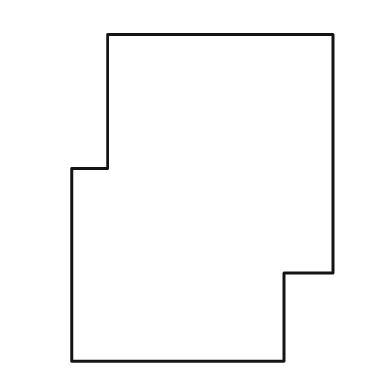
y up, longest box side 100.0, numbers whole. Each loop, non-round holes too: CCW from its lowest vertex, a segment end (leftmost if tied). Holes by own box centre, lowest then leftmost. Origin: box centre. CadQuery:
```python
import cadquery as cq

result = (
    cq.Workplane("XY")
    .moveTo(-40.0, -50.0)
    .lineTo(25.0, -50.0)
    .lineTo(25.0, -23.0)
    .lineTo(40.0, -23.0)
    .lineTo(40.0, 50.0)
    .lineTo(-29.0, 50.0)
    .lineTo(-29.0, 9.0)
    .lineTo(-40.0, 9.0)
    .close()
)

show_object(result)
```